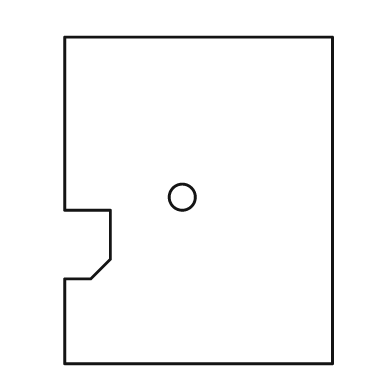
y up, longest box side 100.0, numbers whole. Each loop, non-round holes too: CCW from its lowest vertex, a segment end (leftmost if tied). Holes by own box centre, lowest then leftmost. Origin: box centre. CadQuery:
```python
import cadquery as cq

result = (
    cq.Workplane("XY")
    .moveTo(-41.0, -50.0)
    .lineTo(41.0, -50.0)
    .lineTo(41.0, 50.0)
    .lineTo(-41.0, 50.0)
    .lineTo(-41.0, -3.0)
    .lineTo(-27.0, -3.0)
    .lineTo(-27.0, -18.0)
    .lineTo(-33.0, -24.0)
    .lineTo(-41.0, -24.0)
    .close()
    .moveTo(-5.0, 1.0)
    .circle(4.0)
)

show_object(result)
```